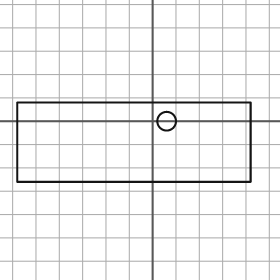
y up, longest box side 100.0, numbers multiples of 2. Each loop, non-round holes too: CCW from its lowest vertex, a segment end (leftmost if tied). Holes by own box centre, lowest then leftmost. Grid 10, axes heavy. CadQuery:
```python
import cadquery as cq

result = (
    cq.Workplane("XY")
    .moveTo(-58.0, -26.0)
    .lineTo(42.0, -26.0)
    .lineTo(42.0, 8.0)
    .lineTo(-58.0, 8.0)
    .close()
    .moveTo(6.0, 0.0)
    .circle(4.0)
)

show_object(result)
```